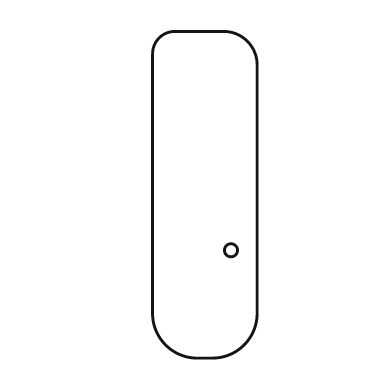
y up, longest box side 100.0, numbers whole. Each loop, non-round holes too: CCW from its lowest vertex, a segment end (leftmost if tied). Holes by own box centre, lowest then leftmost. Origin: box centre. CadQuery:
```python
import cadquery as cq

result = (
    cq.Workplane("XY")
    .moveTo(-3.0, -50.0)
    .lineTo(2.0, -50.0)
    .threePointArc((12.0, -46.0), (16.0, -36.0))
    .lineTo(16.0, 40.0)
    .threePointArc((13.0, 47.0), (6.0, 50.0))
    .lineTo(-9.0, 50.0)
    .threePointArc((-14.0, 48.0), (-16.0, 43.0))
    .lineTo(-16.0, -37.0)
    .threePointArc((-12.0, -46.0), (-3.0, -50.0))
    .close()
    .moveTo(8.0, -17.0)
    .circle(2.0)
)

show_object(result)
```